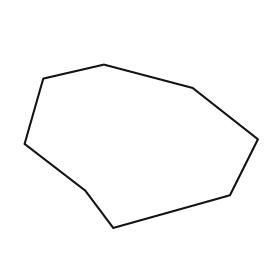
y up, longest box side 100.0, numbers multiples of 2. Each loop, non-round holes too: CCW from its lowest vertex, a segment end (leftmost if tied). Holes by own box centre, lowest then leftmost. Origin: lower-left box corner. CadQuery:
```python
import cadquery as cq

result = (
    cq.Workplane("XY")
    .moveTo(38.0, 0.0)
    .lineTo(88.0, 14.0)
    .lineTo(100.0, 38.0)
    .lineTo(72.0, 60.0)
    .lineTo(34.0, 70.0)
    .lineTo(8.0, 64.0)
    .lineTo(0.0, 36.0)
    .lineTo(26.0, 16.0)
    .close()
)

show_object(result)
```